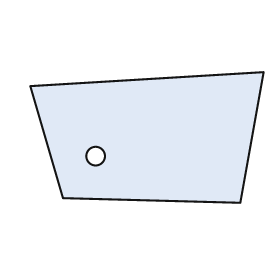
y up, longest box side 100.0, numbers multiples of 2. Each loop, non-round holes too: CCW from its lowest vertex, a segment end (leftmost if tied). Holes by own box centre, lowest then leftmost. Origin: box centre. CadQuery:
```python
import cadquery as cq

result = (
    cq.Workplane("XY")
    .moveTo(40.0, -28.0)
    .lineTo(50.0, 28.0)
    .lineTo(-50.0, 22.0)
    .lineTo(-36.0, -26.0)
    .close()
    .moveTo(-22.0, -8.0)
    .circle(4.0)
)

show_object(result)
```